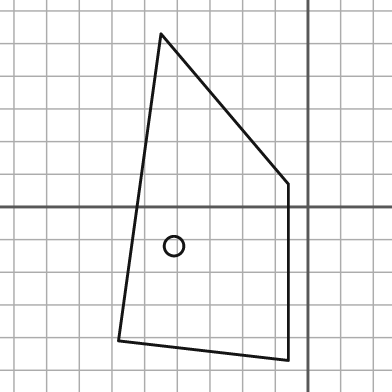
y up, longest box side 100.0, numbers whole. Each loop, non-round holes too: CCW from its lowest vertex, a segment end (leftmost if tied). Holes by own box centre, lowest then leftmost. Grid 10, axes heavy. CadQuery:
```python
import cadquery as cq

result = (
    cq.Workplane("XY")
    .moveTo(-6.0, -47.0)
    .lineTo(-6.0, 7.0)
    .lineTo(-45.0, 53.0)
    .lineTo(-58.0, -41.0)
    .close()
    .moveTo(-41.0, -12.0)
    .circle(3.0)
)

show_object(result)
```